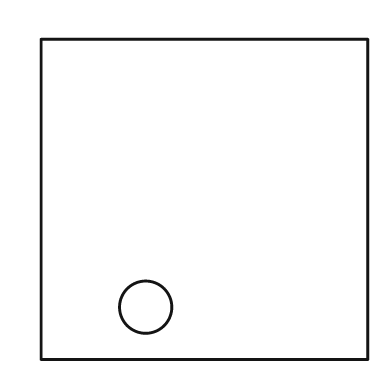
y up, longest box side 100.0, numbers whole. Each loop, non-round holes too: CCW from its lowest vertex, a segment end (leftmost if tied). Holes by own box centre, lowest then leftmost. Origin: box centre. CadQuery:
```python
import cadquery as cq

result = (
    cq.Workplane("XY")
    .moveTo(-50.0, -49.0)
    .lineTo(50.0, -49.0)
    .lineTo(50.0, 49.0)
    .lineTo(-50.0, 49.0)
    .close()
    .moveTo(-18.0, -33.0)
    .circle(8.0)
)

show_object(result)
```